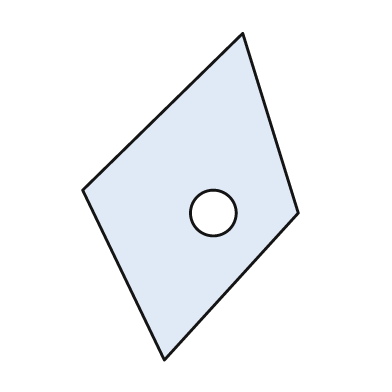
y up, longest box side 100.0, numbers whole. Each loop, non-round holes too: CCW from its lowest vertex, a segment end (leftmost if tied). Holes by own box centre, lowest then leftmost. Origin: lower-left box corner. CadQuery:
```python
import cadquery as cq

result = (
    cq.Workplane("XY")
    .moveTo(25.0, 0.0)
    .lineTo(66.0, 45.0)
    .lineTo(49.0, 100.0)
    .lineTo(0.0, 52.0)
    .close()
    .moveTo(40.0, 45.0)
    .circle(7.0)
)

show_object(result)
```